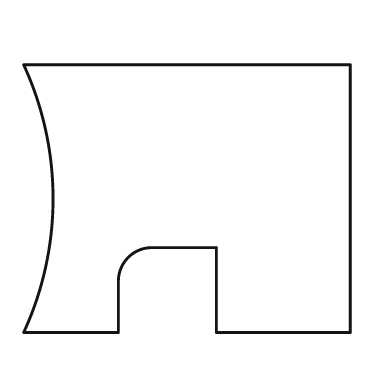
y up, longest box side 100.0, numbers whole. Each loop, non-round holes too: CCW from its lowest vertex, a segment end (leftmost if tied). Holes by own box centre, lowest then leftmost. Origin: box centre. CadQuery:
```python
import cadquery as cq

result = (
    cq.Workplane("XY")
    .moveTo(-50.0, -41.0)
    .lineTo(-21.0, -41.0)
    .lineTo(-21.0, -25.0)
    .threePointArc((-18.0, -18.0), (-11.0, -15.0))
    .lineTo(9.0, -15.0)
    .lineTo(9.0, -41.0)
    .lineTo(50.0, -41.0)
    .lineTo(50.0, 41.0)
    .lineTo(-50.0, 41.0)
    .threePointArc((-41.0, 0.0), (-50.0, -41.0))
    .close()
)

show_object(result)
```